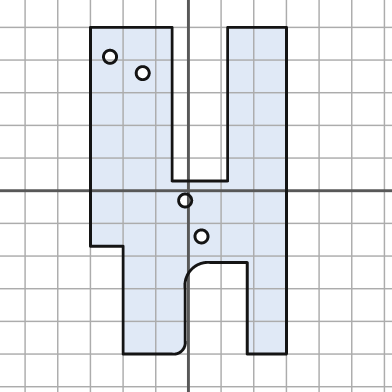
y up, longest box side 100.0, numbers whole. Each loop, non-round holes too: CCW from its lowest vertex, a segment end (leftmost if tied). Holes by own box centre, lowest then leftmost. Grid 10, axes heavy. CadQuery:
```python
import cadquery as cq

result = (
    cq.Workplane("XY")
    .moveTo(-20.0, -50.0)
    .lineTo(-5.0, -50.0)
    .threePointArc((-2.0, -49.0), (-1.0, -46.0))
    .lineTo(-1.0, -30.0)
    .threePointArc((1.0, -24.0), (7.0, -22.0))
    .lineTo(18.0, -22.0)
    .lineTo(18.0, -50.0)
    .lineTo(30.0, -50.0)
    .lineTo(30.0, 50.0)
    .lineTo(12.0, 50.0)
    .lineTo(12.0, 3.0)
    .lineTo(-5.0, 3.0)
    .lineTo(-5.0, 50.0)
    .lineTo(-30.0, 50.0)
    .lineTo(-30.0, -17.0)
    .lineTo(-20.0, -17.0)
    .close()
    .moveTo(4.0, -14.0)
    .circle(2.0)
    .moveTo(-1.0, -3.0)
    .circle(2.0)
    .moveTo(-14.0, 36.0)
    .circle(2.0)
    .moveTo(-24.0, 41.0)
    .circle(2.0)
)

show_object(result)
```